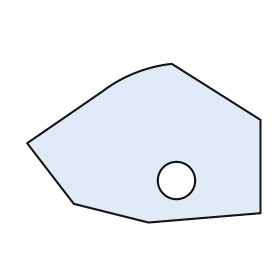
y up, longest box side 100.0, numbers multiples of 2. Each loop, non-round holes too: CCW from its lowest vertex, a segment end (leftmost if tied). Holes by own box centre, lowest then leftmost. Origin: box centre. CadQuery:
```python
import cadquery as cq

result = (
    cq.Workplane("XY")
    .moveTo(2.0, -34.0)
    .lineTo(50.0, -30.0)
    .lineTo(50.0, 10.0)
    .lineTo(12.0, 34.0)
    .threePointArc((-4.0, 30.0), (-18.0, 22.0))
    .lineTo(-50.0, 0.0)
    .lineTo(-30.0, -26.0)
    .close()
    .moveTo(14.0, -16.0)
    .circle(8.0)
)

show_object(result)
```